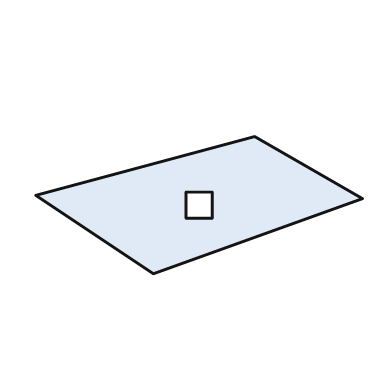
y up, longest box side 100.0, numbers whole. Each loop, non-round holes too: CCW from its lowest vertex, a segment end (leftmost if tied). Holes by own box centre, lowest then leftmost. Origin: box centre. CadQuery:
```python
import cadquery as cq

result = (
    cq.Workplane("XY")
    .moveTo(-14.0, -21.0)
    .lineTo(50.0, 2.0)
    .lineTo(17.0, 21.0)
    .lineTo(-50.0, 3.0)
    .close()
    .moveTo(-4.0, -4.0)
    .lineTo(4.0, -4.0)
    .lineTo(4.0, 4.0)
    .lineTo(-4.0, 4.0)
    .close()
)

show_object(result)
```